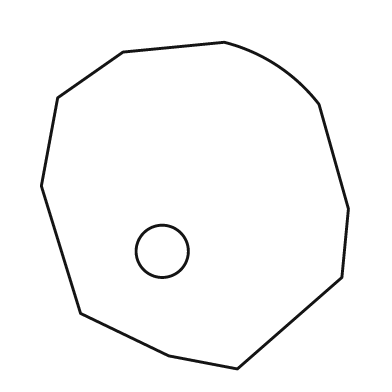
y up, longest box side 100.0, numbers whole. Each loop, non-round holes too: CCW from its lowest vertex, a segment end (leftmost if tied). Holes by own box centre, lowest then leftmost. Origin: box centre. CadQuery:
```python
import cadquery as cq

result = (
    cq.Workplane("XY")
    .moveTo(13.0, -50.0)
    .lineTo(45.0, -22.0)
    .lineTo(47.0, -1.0)
    .lineTo(38.0, 31.0)
    .threePointArc((25.0, 43.0), (9.0, 50.0))
    .lineTo(-22.0, 47.0)
    .lineTo(-42.0, 33.0)
    .lineTo(-47.0, 6.0)
    .lineTo(-35.0, -33.0)
    .lineTo(-8.0, -46.0)
    .close()
    .moveTo(-10.0, -14.0)
    .circle(8.0)
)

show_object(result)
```